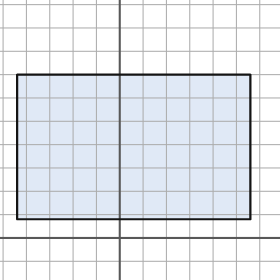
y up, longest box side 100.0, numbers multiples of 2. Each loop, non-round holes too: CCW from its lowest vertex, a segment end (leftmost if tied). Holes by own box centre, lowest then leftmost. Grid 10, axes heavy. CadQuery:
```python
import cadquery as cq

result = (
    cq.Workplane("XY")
    .moveTo(-44.0, 8.0)
    .lineTo(56.0, 8.0)
    .lineTo(56.0, 70.0)
    .lineTo(-44.0, 70.0)
    .close()
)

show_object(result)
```